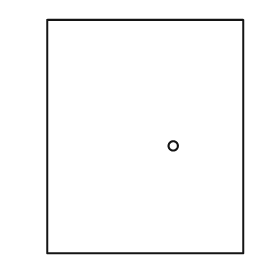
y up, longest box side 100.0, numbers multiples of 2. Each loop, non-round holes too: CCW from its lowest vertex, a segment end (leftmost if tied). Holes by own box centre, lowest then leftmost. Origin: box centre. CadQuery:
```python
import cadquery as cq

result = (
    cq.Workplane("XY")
    .moveTo(-42.0, -50.0)
    .lineTo(42.0, -50.0)
    .lineTo(42.0, 50.0)
    .lineTo(-42.0, 50.0)
    .close()
    .moveTo(12.0, -4.0)
    .circle(2.0)
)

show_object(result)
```